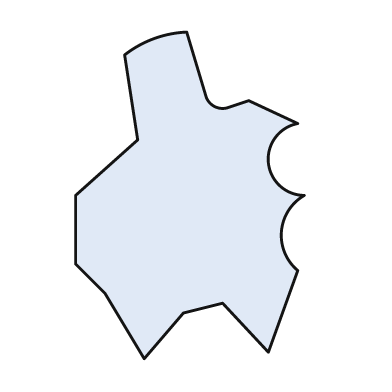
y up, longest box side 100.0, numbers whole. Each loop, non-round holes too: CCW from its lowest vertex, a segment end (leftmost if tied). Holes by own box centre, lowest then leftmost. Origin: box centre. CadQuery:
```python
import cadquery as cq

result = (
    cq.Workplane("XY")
    .moveTo(-14.0, -50.0)
    .lineTo(-2.0, -36.0)
    .lineTo(10.0, -33.0)
    .lineTo(24.0, -48.0)
    .lineTo(33.0, -23.0)
    .threePointArc((28.0, -11.0), (35.0, 0.0))
    .threePointArc((24.0, 10.0), (33.0, 22.0))
    .lineTo(18.0, 29.0)
    .lineTo(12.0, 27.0)
    .threePointArc((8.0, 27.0), (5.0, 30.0))
    .lineTo(-1.0, 50.0)
    .threePointArc((-11.0, 48.0), (-20.0, 43.0))
    .lineTo(-16.0, 17.0)
    .lineTo(-35.0, 0.0)
    .lineTo(-35.0, -21.0)
    .lineTo(-26.0, -30.0)
    .close()
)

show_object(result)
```